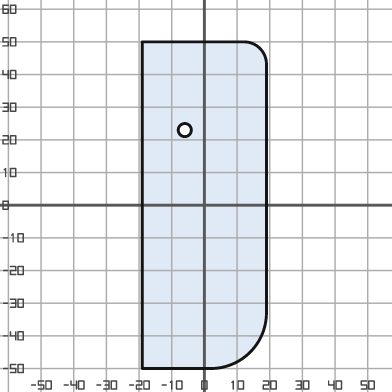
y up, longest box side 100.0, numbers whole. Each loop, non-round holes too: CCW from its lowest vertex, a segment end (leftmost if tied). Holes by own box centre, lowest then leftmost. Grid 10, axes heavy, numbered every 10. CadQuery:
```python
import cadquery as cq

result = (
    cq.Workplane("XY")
    .moveTo(-19.0, -50.0)
    .lineTo(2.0, -50.0)
    .threePointArc((14.0, -45.0), (19.0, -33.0))
    .lineTo(19.0, 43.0)
    .threePointArc((17.0, 48.0), (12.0, 50.0))
    .lineTo(-19.0, 50.0)
    .close()
    .moveTo(-6.0, 23.0)
    .circle(2.0)
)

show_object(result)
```